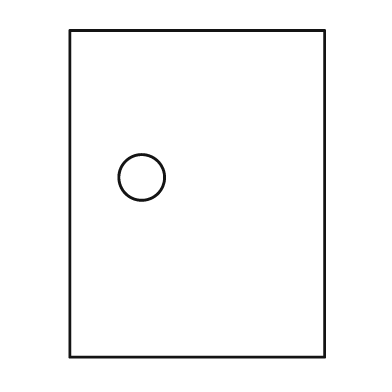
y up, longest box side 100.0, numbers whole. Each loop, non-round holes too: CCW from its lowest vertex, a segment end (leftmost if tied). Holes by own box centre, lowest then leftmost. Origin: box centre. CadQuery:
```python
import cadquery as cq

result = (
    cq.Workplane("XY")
    .moveTo(-39.0, -50.0)
    .lineTo(39.0, -50.0)
    .lineTo(39.0, 50.0)
    .lineTo(-39.0, 50.0)
    .close()
    .moveTo(-17.0, 5.0)
    .circle(7.0)
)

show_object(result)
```